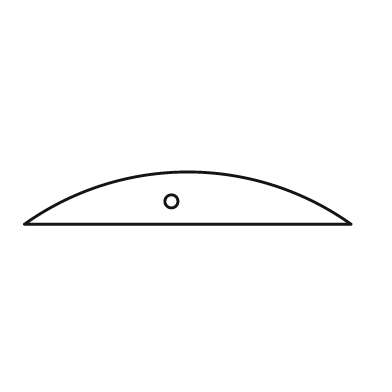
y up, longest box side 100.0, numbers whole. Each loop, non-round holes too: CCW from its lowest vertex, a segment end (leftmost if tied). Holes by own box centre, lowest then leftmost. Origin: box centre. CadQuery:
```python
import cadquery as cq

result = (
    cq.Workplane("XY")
    .moveTo(-50.0, -8.0)
    .lineTo(50.0, -8.0)
    .threePointArc((0.0, 8.0), (-50.0, -8.0))
    .close()
    .moveTo(-5.0, -1.0)
    .circle(2.0)
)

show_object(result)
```